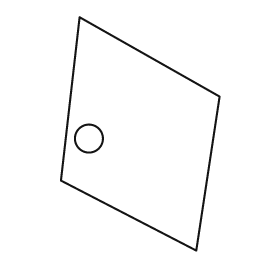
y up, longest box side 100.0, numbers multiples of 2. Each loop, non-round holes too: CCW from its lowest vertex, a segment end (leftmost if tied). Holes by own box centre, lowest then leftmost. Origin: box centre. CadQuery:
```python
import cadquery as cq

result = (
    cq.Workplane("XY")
    .moveTo(24.0, -50.0)
    .lineTo(34.0, 16.0)
    .lineTo(-26.0, 50.0)
    .lineTo(-34.0, -20.0)
    .close()
    .moveTo(-22.0, -2.0)
    .circle(6.0)
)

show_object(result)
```